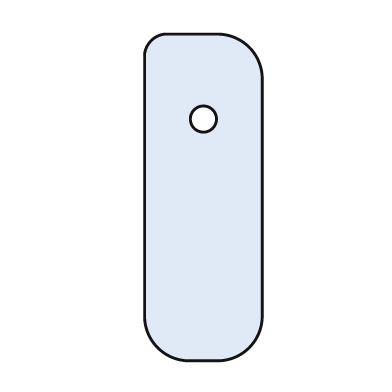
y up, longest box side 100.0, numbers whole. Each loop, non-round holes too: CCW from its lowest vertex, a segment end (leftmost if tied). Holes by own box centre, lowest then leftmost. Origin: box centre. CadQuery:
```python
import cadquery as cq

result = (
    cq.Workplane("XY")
    .moveTo(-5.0, -50.0)
    .lineTo(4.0, -50.0)
    .threePointArc((14.0, -46.0), (18.0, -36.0))
    .lineTo(18.0, 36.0)
    .threePointArc((14.0, 46.0), (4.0, 50.0))
    .lineTo(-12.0, 50.0)
    .threePointArc((-16.0, 48.0), (-18.0, 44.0))
    .lineTo(-18.0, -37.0)
    .threePointArc((-14.0, -46.0), (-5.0, -50.0))
    .close()
    .moveTo(0.0, 24.0)
    .circle(4.0)
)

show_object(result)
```